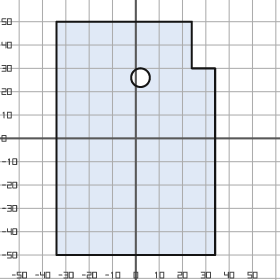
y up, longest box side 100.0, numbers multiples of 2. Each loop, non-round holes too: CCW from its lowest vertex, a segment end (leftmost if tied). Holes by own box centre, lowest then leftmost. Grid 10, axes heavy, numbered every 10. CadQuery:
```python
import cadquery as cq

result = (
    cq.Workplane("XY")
    .moveTo(-34.0, -50.0)
    .lineTo(34.0, -50.0)
    .lineTo(34.0, 30.0)
    .lineTo(24.0, 30.0)
    .lineTo(24.0, 50.0)
    .lineTo(-34.0, 50.0)
    .close()
    .moveTo(2.0, 26.0)
    .circle(4.0)
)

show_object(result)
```